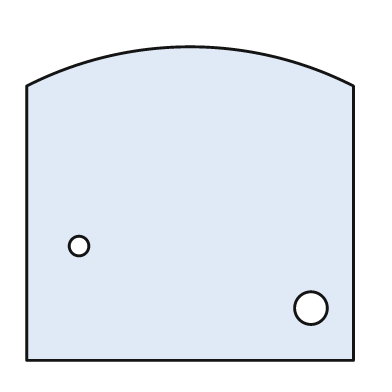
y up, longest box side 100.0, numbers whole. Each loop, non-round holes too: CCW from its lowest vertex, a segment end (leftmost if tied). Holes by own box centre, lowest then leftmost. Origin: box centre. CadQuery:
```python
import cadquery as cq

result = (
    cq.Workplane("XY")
    .moveTo(-50.0, -48.0)
    .lineTo(50.0, -48.0)
    .lineTo(50.0, 36.0)
    .threePointArc((0.0, 48.0), (-50.0, 36.0))
    .close()
    .moveTo(37.0, -32.0)
    .circle(5.0)
    .moveTo(-34.0, -13.0)
    .circle(3.0)
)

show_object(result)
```